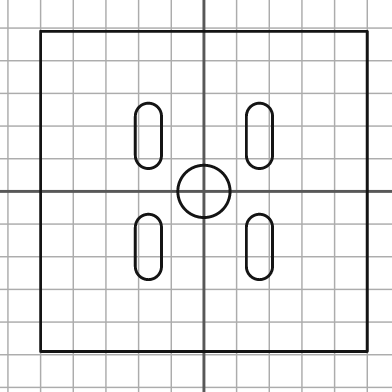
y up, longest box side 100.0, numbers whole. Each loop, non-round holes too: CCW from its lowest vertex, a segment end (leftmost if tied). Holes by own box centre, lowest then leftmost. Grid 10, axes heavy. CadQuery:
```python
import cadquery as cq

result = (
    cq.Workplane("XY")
    .moveTo(-50.0, -49.0)
    .lineTo(50.0, -49.0)
    .lineTo(50.0, 49.0)
    .lineTo(-50.0, 49.0)
    .close()
    .moveTo(-21.0, -23.0)
    .threePointArc((-17.0, -27.0), (-13.0, -23.0))
    .lineTo(-13.0, -11.0)
    .threePointArc((-17.0, -7.0), (-21.0, -11.0))
    .close()
    .moveTo(13.0, -23.0)
    .threePointArc((17.0, -27.0), (21.0, -23.0))
    .lineTo(21.0, -11.0)
    .threePointArc((17.0, -7.0), (13.0, -11.0))
    .close()
    .moveTo(0.0, 0.0)
    .circle(8.0)
    .moveTo(-21.0, 11.0)
    .threePointArc((-17.0, 7.0), (-13.0, 11.0))
    .lineTo(-13.0, 23.0)
    .threePointArc((-17.0, 27.0), (-21.0, 23.0))
    .close()
    .moveTo(13.0, 11.0)
    .threePointArc((17.0, 7.0), (21.0, 11.0))
    .lineTo(21.0, 23.0)
    .threePointArc((17.0, 27.0), (13.0, 23.0))
    .close()
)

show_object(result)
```